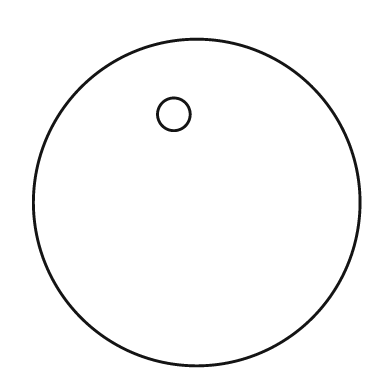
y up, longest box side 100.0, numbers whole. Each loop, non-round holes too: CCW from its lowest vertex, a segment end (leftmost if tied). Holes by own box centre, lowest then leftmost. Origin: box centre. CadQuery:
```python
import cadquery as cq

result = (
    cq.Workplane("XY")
    .moveTo(0.0, 0.0)
    .circle(50.0)
    .moveTo(-7.0, 27.0)
    .circle(5.0)
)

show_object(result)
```